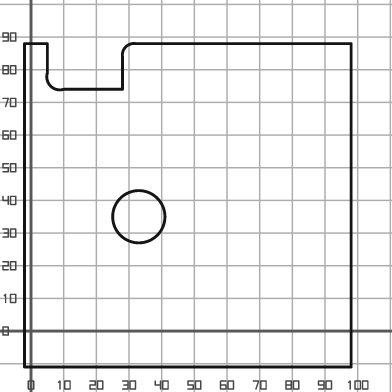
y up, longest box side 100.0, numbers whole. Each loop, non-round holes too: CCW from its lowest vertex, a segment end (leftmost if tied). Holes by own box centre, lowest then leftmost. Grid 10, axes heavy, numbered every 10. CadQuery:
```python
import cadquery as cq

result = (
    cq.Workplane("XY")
    .moveTo(-2.0, -11.0)
    .lineTo(98.0, -11.0)
    .lineTo(98.0, 88.0)
    .lineTo(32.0, 88.0)
    .threePointArc((29.0, 87.0), (28.0, 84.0))
    .lineTo(28.0, 74.0)
    .lineTo(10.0, 74.0)
    .threePointArc((6.0, 75.0), (5.0, 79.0))
    .lineTo(5.0, 88.0)
    .lineTo(-2.0, 88.0)
    .close()
    .moveTo(33.0, 35.0)
    .circle(8.0)
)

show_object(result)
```